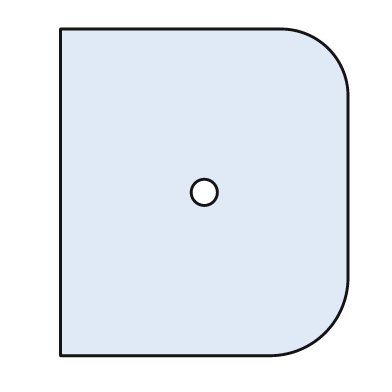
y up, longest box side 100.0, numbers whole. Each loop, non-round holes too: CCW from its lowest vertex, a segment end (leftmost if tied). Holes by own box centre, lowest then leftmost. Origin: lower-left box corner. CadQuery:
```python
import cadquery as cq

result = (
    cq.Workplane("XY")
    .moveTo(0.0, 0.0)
    .lineTo(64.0, 0.0)
    .threePointArc((81.0, 7.0), (88.0, 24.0))
    .lineTo(88.0, 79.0)
    .threePointArc((82.0, 94.0), (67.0, 100.0))
    .lineTo(0.0, 100.0)
    .close()
    .moveTo(44.0, 50.0)
    .circle(4.0)
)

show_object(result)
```